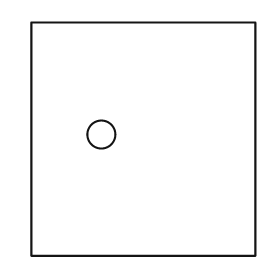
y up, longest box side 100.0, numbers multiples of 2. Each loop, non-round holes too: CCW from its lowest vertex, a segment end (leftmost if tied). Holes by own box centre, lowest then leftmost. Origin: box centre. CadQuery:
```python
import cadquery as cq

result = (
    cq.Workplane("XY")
    .moveTo(-48.0, -50.0)
    .lineTo(48.0, -50.0)
    .lineTo(48.0, 50.0)
    .lineTo(-48.0, 50.0)
    .close()
    .moveTo(-18.0, 2.0)
    .circle(6.0)
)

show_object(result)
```